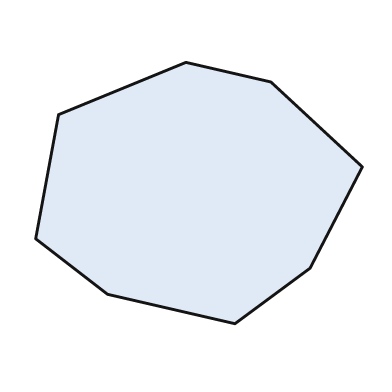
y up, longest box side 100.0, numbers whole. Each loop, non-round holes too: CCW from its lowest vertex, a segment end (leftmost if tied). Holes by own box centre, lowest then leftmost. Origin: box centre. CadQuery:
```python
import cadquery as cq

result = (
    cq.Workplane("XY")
    .moveTo(11.0, -40.0)
    .lineTo(34.0, -23.0)
    .lineTo(50.0, 8.0)
    .lineTo(22.0, 34.0)
    .lineTo(-4.0, 40.0)
    .lineTo(-43.0, 24.0)
    .lineTo(-50.0, -14.0)
    .lineTo(-28.0, -31.0)
    .close()
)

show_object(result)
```